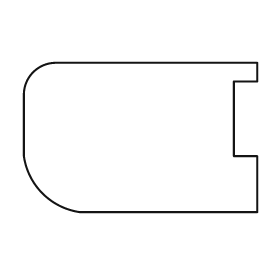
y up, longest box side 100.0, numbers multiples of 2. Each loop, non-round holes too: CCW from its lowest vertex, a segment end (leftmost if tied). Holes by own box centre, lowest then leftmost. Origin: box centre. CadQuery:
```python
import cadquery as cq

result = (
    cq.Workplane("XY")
    .moveTo(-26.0, -32.0)
    .lineTo(50.0, -32.0)
    .lineTo(50.0, -8.0)
    .lineTo(40.0, -8.0)
    .lineTo(40.0, 24.0)
    .lineTo(50.0, 24.0)
    .lineTo(50.0, 32.0)
    .lineTo(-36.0, 32.0)
    .threePointArc((-46.0, 28.0), (-50.0, 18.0))
    .lineTo(-50.0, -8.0)
    .threePointArc((-42.0, -24.0), (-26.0, -32.0))
    .close()
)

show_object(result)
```